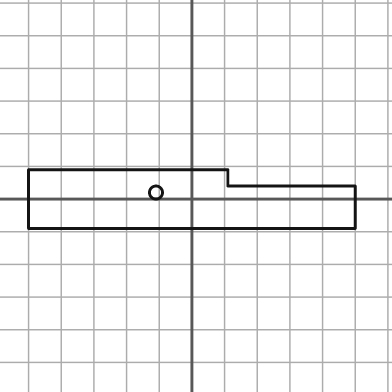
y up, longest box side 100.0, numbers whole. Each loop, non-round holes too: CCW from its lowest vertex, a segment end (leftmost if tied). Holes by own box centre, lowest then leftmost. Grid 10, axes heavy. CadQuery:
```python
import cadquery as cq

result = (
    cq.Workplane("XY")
    .moveTo(-50.0, -9.0)
    .lineTo(50.0, -9.0)
    .lineTo(50.0, 4.0)
    .lineTo(11.0, 4.0)
    .lineTo(11.0, 9.0)
    .lineTo(-50.0, 9.0)
    .close()
    .moveTo(-11.0, 2.0)
    .circle(2.0)
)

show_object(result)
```